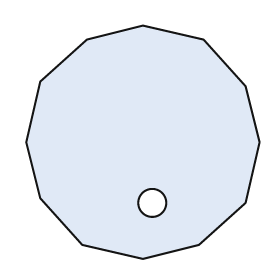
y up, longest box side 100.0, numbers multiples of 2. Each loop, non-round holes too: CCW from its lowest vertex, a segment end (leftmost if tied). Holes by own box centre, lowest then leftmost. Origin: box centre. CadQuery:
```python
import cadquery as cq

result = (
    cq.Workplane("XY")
    .moveTo(0.0, -50.0)
    .lineTo(24.0, -44.0)
    .lineTo(44.0, -26.0)
    .lineTo(50.0, 0.0)
    .lineTo(44.0, 24.0)
    .lineTo(26.0, 44.0)
    .lineTo(0.0, 50.0)
    .lineTo(-24.0, 44.0)
    .lineTo(-44.0, 26.0)
    .lineTo(-50.0, 0.0)
    .lineTo(-44.0, -24.0)
    .lineTo(-26.0, -44.0)
    .close()
    .moveTo(4.0, -26.0)
    .circle(6.0)
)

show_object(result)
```